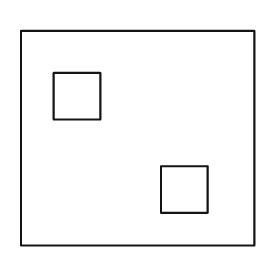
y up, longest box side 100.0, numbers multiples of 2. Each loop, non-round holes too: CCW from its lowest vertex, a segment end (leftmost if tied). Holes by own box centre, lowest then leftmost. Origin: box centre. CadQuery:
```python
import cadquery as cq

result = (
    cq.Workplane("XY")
    .moveTo(-50.0, -46.0)
    .lineTo(50.0, -46.0)
    .lineTo(50.0, 46.0)
    .lineTo(-50.0, 46.0)
    .close()
    .moveTo(10.0, -32.0)
    .lineTo(30.0, -32.0)
    .lineTo(30.0, -12.0)
    .lineTo(10.0, -12.0)
    .close()
    .moveTo(-36.0, 8.0)
    .lineTo(-16.0, 8.0)
    .lineTo(-16.0, 28.0)
    .lineTo(-36.0, 28.0)
    .close()
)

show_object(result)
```